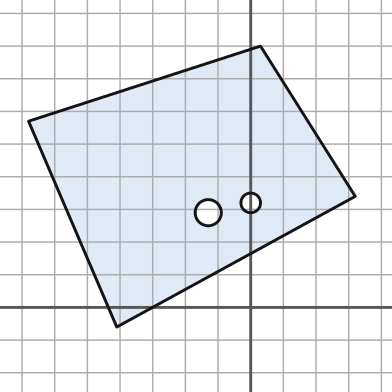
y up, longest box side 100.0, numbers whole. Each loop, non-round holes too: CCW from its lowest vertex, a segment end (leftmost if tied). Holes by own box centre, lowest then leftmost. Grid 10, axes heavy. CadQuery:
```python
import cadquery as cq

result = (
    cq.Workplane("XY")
    .moveTo(-41.0, -6.0)
    .lineTo(32.0, 34.0)
    .lineTo(3.0, 80.0)
    .lineTo(-68.0, 57.0)
    .close()
    .moveTo(-13.0, 29.0)
    .circle(4.0)
    .moveTo(0.0, 32.0)
    .circle(3.0)
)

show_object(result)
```